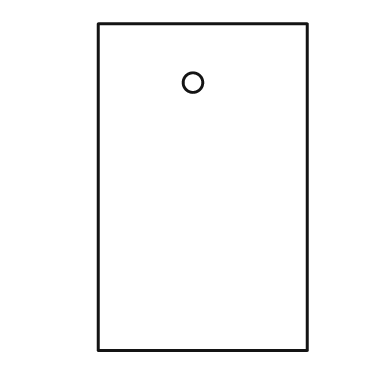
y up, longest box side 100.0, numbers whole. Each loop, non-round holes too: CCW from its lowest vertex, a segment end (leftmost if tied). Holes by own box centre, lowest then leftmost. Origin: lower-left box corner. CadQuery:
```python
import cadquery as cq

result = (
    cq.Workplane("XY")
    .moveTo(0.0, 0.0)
    .lineTo(64.0, 0.0)
    .lineTo(64.0, 100.0)
    .lineTo(0.0, 100.0)
    .close()
    .moveTo(29.0, 82.0)
    .circle(3.0)
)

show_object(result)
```